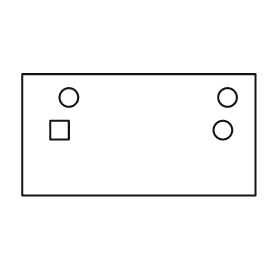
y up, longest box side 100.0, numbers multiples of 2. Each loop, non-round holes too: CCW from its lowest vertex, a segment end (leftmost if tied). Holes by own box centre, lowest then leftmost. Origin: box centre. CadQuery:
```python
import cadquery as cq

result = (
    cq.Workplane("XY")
    .moveTo(-50.0, -26.0)
    .lineTo(50.0, -26.0)
    .lineTo(50.0, 26.0)
    .lineTo(-50.0, 26.0)
    .close()
    .moveTo(-38.0, -2.0)
    .lineTo(-30.0, -2.0)
    .lineTo(-30.0, 6.0)
    .lineTo(-38.0, 6.0)
    .close()
    .moveTo(36.0, 2.0)
    .circle(4.0)
    .moveTo(-30.0, 16.0)
    .circle(4.0)
    .moveTo(38.0, 16.0)
    .circle(4.0)
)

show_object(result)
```